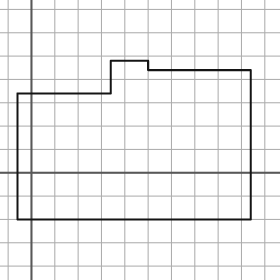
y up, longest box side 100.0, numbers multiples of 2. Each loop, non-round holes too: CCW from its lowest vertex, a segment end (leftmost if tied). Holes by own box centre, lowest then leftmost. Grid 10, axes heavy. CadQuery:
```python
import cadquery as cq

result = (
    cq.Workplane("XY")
    .moveTo(-6.0, -20.0)
    .lineTo(94.0, -20.0)
    .lineTo(94.0, 44.0)
    .lineTo(50.0, 44.0)
    .lineTo(50.0, 48.0)
    .lineTo(34.0, 48.0)
    .lineTo(34.0, 34.0)
    .lineTo(-6.0, 34.0)
    .close()
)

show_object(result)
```